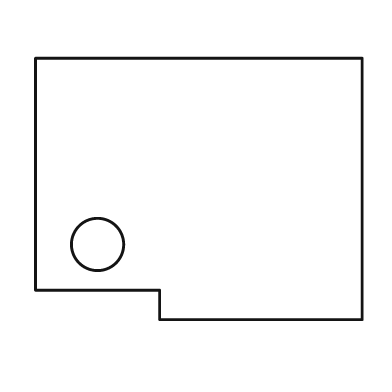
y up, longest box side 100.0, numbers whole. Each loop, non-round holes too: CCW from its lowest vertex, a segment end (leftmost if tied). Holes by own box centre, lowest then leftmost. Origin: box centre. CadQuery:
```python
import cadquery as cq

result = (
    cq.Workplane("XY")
    .moveTo(-12.0, -40.0)
    .lineTo(50.0, -40.0)
    .lineTo(50.0, 40.0)
    .lineTo(-50.0, 40.0)
    .lineTo(-50.0, -31.0)
    .lineTo(-12.0, -31.0)
    .close()
    .moveTo(-31.0, -17.0)
    .circle(8.0)
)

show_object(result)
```